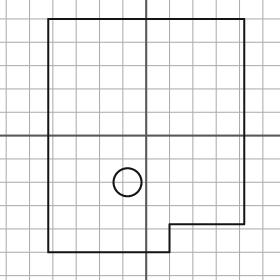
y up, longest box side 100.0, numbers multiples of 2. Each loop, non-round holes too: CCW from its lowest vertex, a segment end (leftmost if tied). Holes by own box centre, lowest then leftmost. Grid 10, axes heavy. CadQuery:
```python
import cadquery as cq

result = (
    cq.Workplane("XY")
    .moveTo(-42.0, -50.0)
    .lineTo(10.0, -50.0)
    .lineTo(10.0, -38.0)
    .lineTo(42.0, -38.0)
    .lineTo(42.0, 50.0)
    .lineTo(-42.0, 50.0)
    .close()
    .moveTo(-8.0, -20.0)
    .circle(6.0)
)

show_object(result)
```